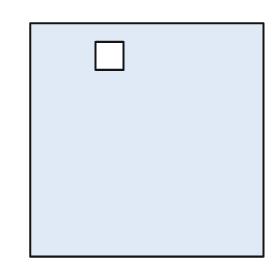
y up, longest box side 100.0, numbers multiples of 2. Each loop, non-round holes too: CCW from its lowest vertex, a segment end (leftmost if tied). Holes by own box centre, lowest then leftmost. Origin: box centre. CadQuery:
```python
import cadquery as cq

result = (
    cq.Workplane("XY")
    .moveTo(-50.0, -50.0)
    .lineTo(50.0, -50.0)
    .lineTo(50.0, 50.0)
    .lineTo(-50.0, 50.0)
    .close()
    .moveTo(-22.0, 30.0)
    .lineTo(-10.0, 30.0)
    .lineTo(-10.0, 42.0)
    .lineTo(-22.0, 42.0)
    .close()
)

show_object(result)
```